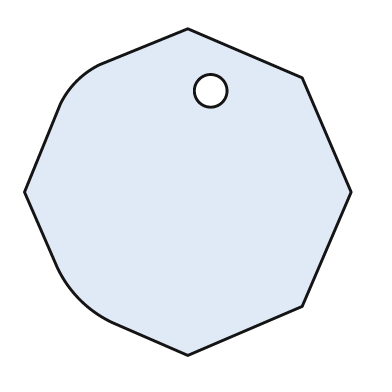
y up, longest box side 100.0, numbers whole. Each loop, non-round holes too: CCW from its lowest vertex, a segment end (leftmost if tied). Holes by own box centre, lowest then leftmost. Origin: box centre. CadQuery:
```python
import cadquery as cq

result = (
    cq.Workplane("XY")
    .moveTo(0.0, -50.0)
    .lineTo(35.0, -35.0)
    .lineTo(50.0, 0.0)
    .lineTo(35.0, 35.0)
    .lineTo(0.0, 50.0)
    .lineTo(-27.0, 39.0)
    .threePointArc((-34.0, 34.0), (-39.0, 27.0))
    .lineTo(-50.0, 0.0)
    .lineTo(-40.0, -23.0)
    .threePointArc((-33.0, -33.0), (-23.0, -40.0))
    .close()
    .moveTo(7.0, 31.0)
    .circle(5.0)
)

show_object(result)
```